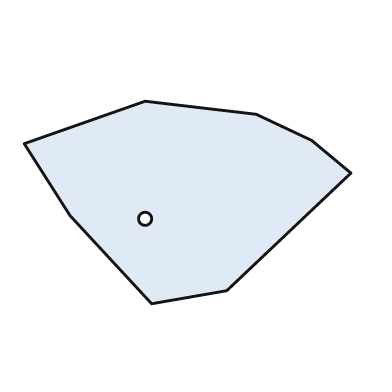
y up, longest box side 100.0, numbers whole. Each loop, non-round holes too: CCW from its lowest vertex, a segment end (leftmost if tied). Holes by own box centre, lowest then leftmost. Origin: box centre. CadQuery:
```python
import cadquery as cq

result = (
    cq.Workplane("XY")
    .moveTo(-11.0, -31.0)
    .lineTo(12.0, -27.0)
    .lineTo(50.0, 9.0)
    .lineTo(38.0, 19.0)
    .lineTo(21.0, 27.0)
    .lineTo(-13.0, 31.0)
    .lineTo(-50.0, 18.0)
    .lineTo(-36.0, -4.0)
    .close()
    .moveTo(-13.0, -5.0)
    .circle(2.0)
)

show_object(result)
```